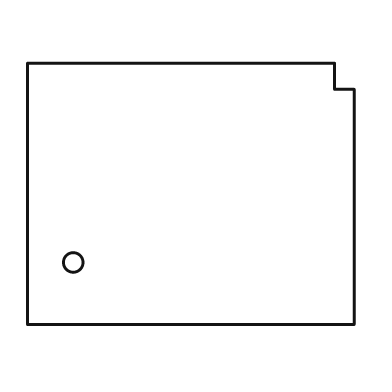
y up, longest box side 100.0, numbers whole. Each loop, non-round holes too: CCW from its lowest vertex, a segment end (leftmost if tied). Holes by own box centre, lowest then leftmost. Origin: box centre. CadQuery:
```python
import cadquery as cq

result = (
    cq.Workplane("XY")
    .moveTo(-50.0, -40.0)
    .lineTo(50.0, -40.0)
    .lineTo(50.0, 32.0)
    .lineTo(44.0, 32.0)
    .lineTo(44.0, 40.0)
    .lineTo(-50.0, 40.0)
    .close()
    .moveTo(-36.0, -21.0)
    .circle(3.0)
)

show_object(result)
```